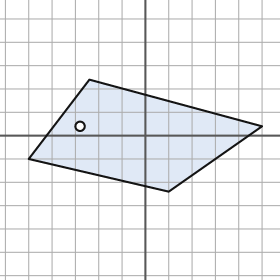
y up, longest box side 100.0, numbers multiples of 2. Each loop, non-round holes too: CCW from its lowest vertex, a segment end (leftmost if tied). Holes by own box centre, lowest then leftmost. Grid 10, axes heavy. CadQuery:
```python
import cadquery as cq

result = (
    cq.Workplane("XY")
    .moveTo(10.0, -24.0)
    .lineTo(50.0, 4.0)
    .lineTo(-24.0, 24.0)
    .lineTo(-50.0, -10.0)
    .close()
    .moveTo(-28.0, 4.0)
    .circle(2.0)
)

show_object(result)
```